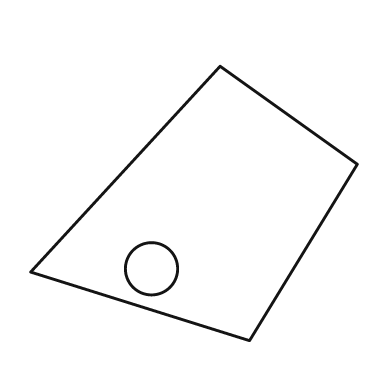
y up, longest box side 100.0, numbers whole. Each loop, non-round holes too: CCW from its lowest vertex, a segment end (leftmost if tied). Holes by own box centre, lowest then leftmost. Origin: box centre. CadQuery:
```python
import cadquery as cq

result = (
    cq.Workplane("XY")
    .moveTo(17.0, -42.0)
    .lineTo(50.0, 12.0)
    .lineTo(8.0, 42.0)
    .lineTo(-50.0, -21.0)
    .close()
    .moveTo(-13.0, -20.0)
    .circle(8.0)
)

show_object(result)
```